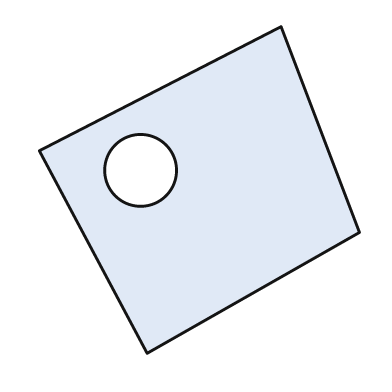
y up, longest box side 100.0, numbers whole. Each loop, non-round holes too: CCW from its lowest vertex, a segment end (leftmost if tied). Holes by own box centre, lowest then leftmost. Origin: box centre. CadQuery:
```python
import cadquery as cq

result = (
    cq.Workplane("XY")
    .moveTo(-16.0, -50.0)
    .lineTo(49.0, -13.0)
    .lineTo(25.0, 50.0)
    .lineTo(-49.0, 12.0)
    .close()
    .moveTo(-18.0, 6.0)
    .circle(11.0)
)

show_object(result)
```